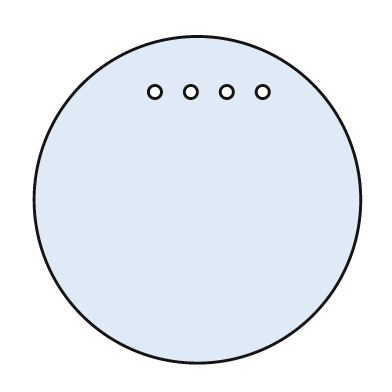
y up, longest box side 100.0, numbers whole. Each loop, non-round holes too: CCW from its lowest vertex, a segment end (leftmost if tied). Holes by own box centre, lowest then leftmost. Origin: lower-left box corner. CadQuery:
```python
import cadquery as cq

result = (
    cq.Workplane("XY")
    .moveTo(50.0, 50.0)
    .circle(50.0)
    .moveTo(37.0, 83.0)
    .circle(2.0)
    .moveTo(48.0, 83.0)
    .circle(2.0)
    .moveTo(59.0, 83.0)
    .circle(2.0)
    .moveTo(70.0, 83.0)
    .circle(2.0)
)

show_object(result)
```